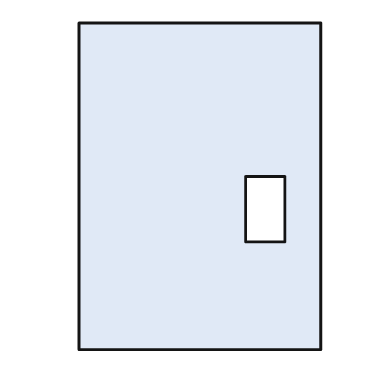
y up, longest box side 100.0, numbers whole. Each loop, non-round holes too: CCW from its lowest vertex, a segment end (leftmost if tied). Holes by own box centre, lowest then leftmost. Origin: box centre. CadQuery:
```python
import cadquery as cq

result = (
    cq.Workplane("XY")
    .moveTo(-37.0, -50.0)
    .lineTo(37.0, -50.0)
    .lineTo(37.0, 50.0)
    .lineTo(-37.0, 50.0)
    .close()
    .moveTo(14.0, -17.0)
    .lineTo(26.0, -17.0)
    .lineTo(26.0, 3.0)
    .lineTo(14.0, 3.0)
    .close()
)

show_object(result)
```